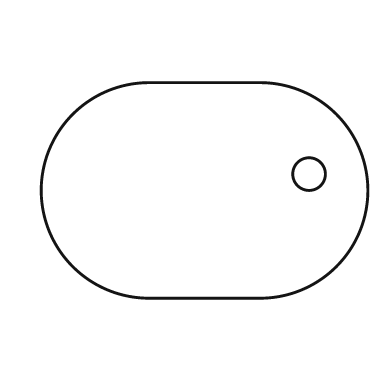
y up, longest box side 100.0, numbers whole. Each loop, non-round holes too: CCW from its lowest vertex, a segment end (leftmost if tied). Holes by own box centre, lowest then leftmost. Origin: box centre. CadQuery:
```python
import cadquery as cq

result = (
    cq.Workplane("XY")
    .moveTo(-17.0, -33.0)
    .lineTo(17.0, -33.0)
    .threePointArc((50.0, 0.0), (17.0, 33.0))
    .lineTo(-17.0, 33.0)
    .threePointArc((-50.0, 0.0), (-17.0, -33.0))
    .close()
    .moveTo(32.0, 5.0)
    .circle(5.0)
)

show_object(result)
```